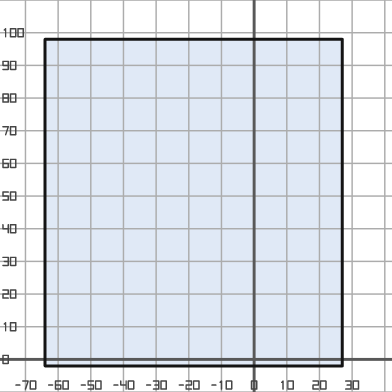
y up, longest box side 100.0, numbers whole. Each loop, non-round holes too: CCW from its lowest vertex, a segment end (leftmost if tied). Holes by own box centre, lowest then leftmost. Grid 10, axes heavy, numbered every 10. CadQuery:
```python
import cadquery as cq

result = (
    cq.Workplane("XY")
    .moveTo(-64.0, -2.0)
    .lineTo(27.0, -2.0)
    .lineTo(27.0, 98.0)
    .lineTo(-64.0, 98.0)
    .close()
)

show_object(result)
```